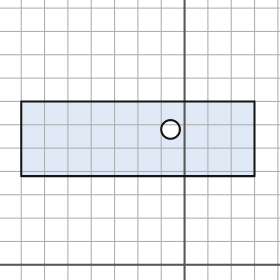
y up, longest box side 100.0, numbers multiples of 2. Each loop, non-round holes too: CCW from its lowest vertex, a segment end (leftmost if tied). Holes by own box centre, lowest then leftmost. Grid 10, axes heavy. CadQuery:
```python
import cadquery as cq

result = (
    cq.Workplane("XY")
    .moveTo(-70.0, 38.0)
    .lineTo(30.0, 38.0)
    .lineTo(30.0, 70.0)
    .lineTo(-70.0, 70.0)
    .close()
    .moveTo(-6.0, 58.0)
    .circle(4.0)
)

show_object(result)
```